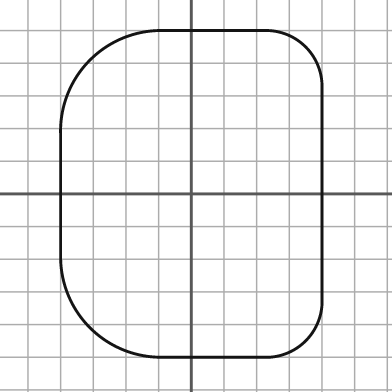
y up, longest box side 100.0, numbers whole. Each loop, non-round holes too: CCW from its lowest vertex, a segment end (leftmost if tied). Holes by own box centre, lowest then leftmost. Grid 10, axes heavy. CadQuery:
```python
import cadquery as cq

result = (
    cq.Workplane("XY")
    .moveTo(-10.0, -50.0)
    .lineTo(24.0, -50.0)
    .threePointArc((35.0, -45.0), (40.0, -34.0))
    .lineTo(40.0, 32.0)
    .threePointArc((35.0, 45.0), (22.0, 50.0))
    .lineTo(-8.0, 50.0)
    .threePointArc((-31.0, 41.0), (-40.0, 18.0))
    .lineTo(-40.0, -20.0)
    .threePointArc((-31.0, -41.0), (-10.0, -50.0))
    .close()
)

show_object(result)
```